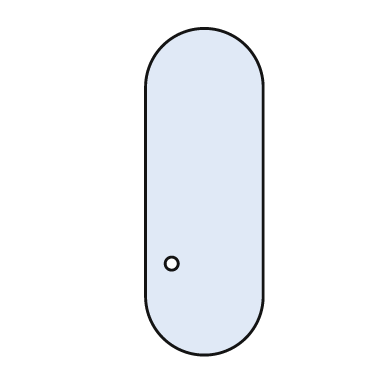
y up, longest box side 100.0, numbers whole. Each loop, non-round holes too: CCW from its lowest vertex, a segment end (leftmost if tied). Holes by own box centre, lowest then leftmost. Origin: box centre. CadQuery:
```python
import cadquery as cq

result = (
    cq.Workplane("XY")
    .moveTo(-18.0, -32.0)
    .threePointArc((0.0, -50.0), (18.0, -32.0))
    .lineTo(18.0, 32.0)
    .threePointArc((0.0, 50.0), (-18.0, 32.0))
    .close()
    .moveTo(-10.0, -22.0)
    .circle(2.0)
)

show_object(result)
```